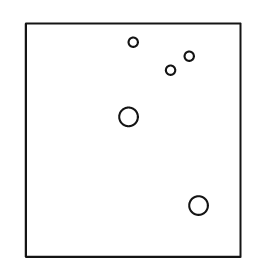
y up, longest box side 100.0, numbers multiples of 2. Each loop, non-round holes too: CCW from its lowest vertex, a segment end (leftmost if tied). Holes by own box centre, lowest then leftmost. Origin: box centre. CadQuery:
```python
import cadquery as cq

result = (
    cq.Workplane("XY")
    .moveTo(-46.0, -50.0)
    .lineTo(46.0, -50.0)
    .lineTo(46.0, 50.0)
    .lineTo(-46.0, 50.0)
    .close()
    .moveTo(28.0, -28.0)
    .circle(4.0)
    .moveTo(-2.0, 10.0)
    .circle(4.0)
    .moveTo(16.0, 30.0)
    .circle(2.0)
    .moveTo(24.0, 36.0)
    .circle(2.0)
    .moveTo(0.0, 42.0)
    .circle(2.0)
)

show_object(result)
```